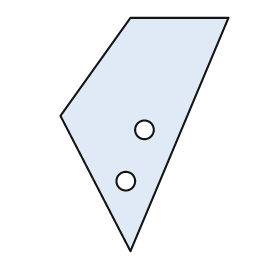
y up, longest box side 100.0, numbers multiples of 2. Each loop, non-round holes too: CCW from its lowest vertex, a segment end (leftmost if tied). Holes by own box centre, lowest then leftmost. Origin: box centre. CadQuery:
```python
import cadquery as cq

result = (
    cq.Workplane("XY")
    .moveTo(-6.0, -50.0)
    .lineTo(36.0, 50.0)
    .lineTo(-6.0, 50.0)
    .lineTo(-36.0, 8.0)
    .close()
    .moveTo(-8.0, -20.0)
    .circle(4.0)
    .moveTo(0.0, 2.0)
    .circle(4.0)
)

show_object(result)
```